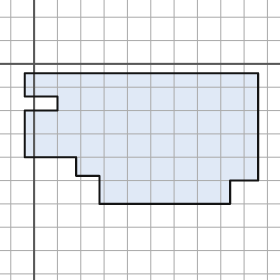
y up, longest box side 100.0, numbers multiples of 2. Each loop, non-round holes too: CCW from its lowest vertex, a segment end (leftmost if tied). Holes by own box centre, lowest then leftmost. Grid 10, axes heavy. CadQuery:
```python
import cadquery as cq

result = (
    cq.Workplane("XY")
    .moveTo(28.0, -60.0)
    .lineTo(84.0, -60.0)
    .lineTo(84.0, -50.0)
    .lineTo(96.0, -50.0)
    .lineTo(96.0, -4.0)
    .lineTo(-4.0, -4.0)
    .lineTo(-4.0, -14.0)
    .lineTo(10.0, -14.0)
    .lineTo(10.0, -20.0)
    .lineTo(-4.0, -20.0)
    .lineTo(-4.0, -40.0)
    .lineTo(18.0, -40.0)
    .lineTo(18.0, -48.0)
    .lineTo(28.0, -48.0)
    .close()
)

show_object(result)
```